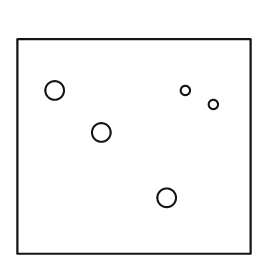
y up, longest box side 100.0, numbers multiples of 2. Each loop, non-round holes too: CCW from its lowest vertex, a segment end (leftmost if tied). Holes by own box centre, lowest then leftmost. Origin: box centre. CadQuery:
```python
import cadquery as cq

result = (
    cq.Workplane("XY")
    .moveTo(-50.0, -46.0)
    .lineTo(50.0, -46.0)
    .lineTo(50.0, 46.0)
    .lineTo(-50.0, 46.0)
    .close()
    .moveTo(14.0, -22.0)
    .circle(4.0)
    .moveTo(-14.0, 6.0)
    .circle(4.0)
    .moveTo(34.0, 18.0)
    .circle(2.0)
    .moveTo(-34.0, 24.0)
    .circle(4.0)
    .moveTo(22.0, 24.0)
    .circle(2.0)
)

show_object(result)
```